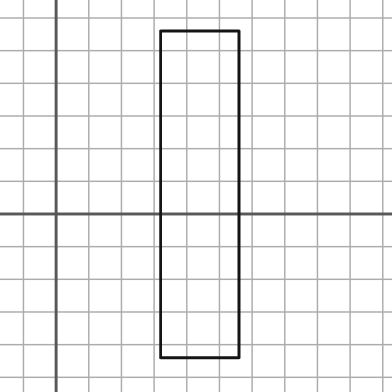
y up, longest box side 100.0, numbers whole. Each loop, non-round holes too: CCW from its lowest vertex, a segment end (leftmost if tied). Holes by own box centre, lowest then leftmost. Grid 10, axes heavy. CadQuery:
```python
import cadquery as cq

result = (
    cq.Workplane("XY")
    .moveTo(32.0, -44.0)
    .lineTo(56.0, -44.0)
    .lineTo(56.0, 56.0)
    .lineTo(32.0, 56.0)
    .close()
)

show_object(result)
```